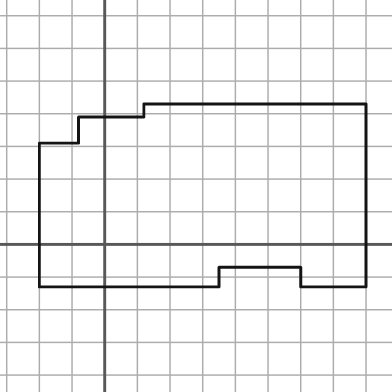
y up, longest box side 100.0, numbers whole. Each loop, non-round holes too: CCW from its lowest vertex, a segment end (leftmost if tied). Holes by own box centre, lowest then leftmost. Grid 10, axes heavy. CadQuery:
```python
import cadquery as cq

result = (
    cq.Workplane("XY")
    .moveTo(-20.0, -13.0)
    .lineTo(35.0, -13.0)
    .lineTo(35.0, -7.0)
    .lineTo(60.0, -7.0)
    .lineTo(60.0, -13.0)
    .lineTo(80.0, -13.0)
    .lineTo(80.0, 43.0)
    .lineTo(12.0, 43.0)
    .lineTo(12.0, 39.0)
    .lineTo(-8.0, 39.0)
    .lineTo(-8.0, 31.0)
    .lineTo(-20.0, 31.0)
    .close()
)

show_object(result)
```